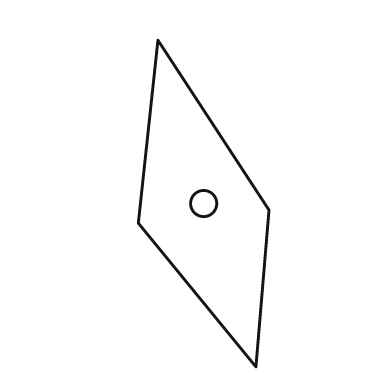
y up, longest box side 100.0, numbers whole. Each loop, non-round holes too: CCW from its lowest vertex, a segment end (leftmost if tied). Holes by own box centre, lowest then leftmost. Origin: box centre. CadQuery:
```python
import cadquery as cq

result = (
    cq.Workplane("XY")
    .moveTo(16.0, -50.0)
    .lineTo(20.0, -2.0)
    .lineTo(-14.0, 50.0)
    .lineTo(-20.0, -6.0)
    .close()
    .moveTo(0.0, 0.0)
    .circle(4.0)
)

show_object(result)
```